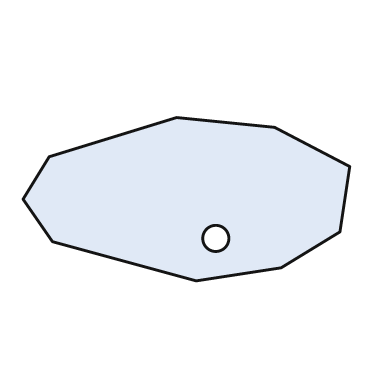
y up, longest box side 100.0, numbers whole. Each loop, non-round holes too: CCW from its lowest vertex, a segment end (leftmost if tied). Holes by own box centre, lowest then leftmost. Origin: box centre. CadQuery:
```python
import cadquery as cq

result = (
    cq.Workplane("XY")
    .moveTo(3.0, -25.0)
    .lineTo(29.0, -21.0)
    .lineTo(47.0, -10.0)
    .lineTo(50.0, 10.0)
    .lineTo(27.0, 22.0)
    .lineTo(-3.0, 25.0)
    .lineTo(-42.0, 13.0)
    .lineTo(-50.0, 0.0)
    .lineTo(-41.0, -13.0)
    .close()
    .moveTo(9.0, -12.0)
    .circle(4.0)
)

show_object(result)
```